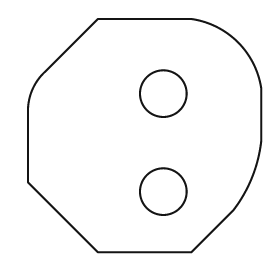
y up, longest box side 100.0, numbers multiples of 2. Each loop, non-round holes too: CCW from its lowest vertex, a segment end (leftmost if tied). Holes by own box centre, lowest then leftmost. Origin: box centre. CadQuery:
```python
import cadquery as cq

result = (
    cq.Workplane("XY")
    .moveTo(-20.0, -50.0)
    .lineTo(20.0, -50.0)
    .lineTo(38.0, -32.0)
    .threePointArc((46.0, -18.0), (50.0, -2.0))
    .lineTo(50.0, 20.0)
    .threePointArc((40.0, 40.0), (20.0, 50.0))
    .lineTo(-20.0, 50.0)
    .lineTo(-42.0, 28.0)
    .threePointArc((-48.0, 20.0), (-50.0, 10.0))
    .lineTo(-50.0, -20.0)
    .close()
    .moveTo(8.0, -24.0)
    .circle(10.0)
    .moveTo(8.0, 18.0)
    .circle(10.0)
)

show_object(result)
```